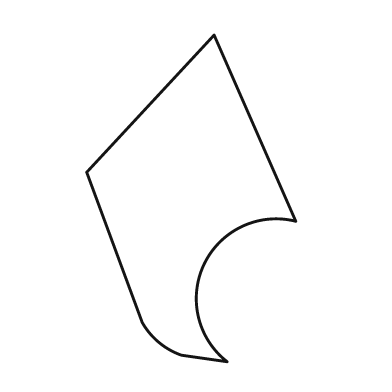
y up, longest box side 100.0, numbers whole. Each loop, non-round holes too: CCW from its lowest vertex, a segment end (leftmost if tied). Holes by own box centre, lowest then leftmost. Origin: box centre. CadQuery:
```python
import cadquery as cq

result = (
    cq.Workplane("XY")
    .moveTo(11.0, -50.0)
    .threePointArc((4.0, -20.0), (32.0, -7.0))
    .lineTo(7.0, 50.0)
    .lineTo(-32.0, 8.0)
    .lineTo(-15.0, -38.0)
    .threePointArc((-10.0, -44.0), (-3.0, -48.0))
    .close()
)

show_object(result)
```